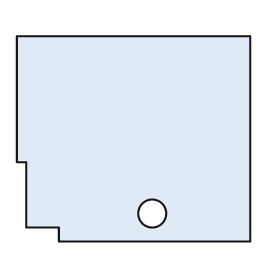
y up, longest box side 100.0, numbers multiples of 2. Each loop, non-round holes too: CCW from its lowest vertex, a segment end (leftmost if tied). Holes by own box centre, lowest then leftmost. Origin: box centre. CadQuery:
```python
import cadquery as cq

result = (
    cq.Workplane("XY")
    .moveTo(-32.0, -44.0)
    .lineTo(50.0, -44.0)
    .lineTo(50.0, 44.0)
    .lineTo(-50.0, 44.0)
    .lineTo(-50.0, -10.0)
    .lineTo(-46.0, -10.0)
    .lineTo(-46.0, -38.0)
    .lineTo(-32.0, -38.0)
    .close()
    .moveTo(8.0, -32.0)
    .circle(6.0)
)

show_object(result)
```